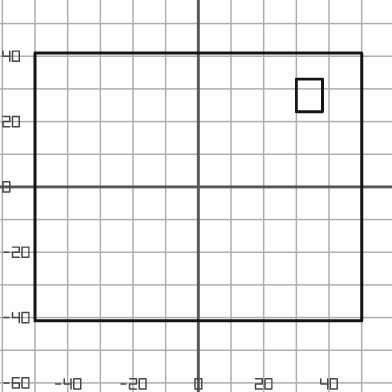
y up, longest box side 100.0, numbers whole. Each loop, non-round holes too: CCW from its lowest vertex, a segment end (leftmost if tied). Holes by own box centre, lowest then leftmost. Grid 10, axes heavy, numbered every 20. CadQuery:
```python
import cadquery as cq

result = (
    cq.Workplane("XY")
    .moveTo(-50.0, -41.0)
    .lineTo(50.0, -41.0)
    .lineTo(50.0, 41.0)
    .lineTo(-50.0, 41.0)
    .close()
    .moveTo(30.0, 23.0)
    .lineTo(38.0, 23.0)
    .lineTo(38.0, 33.0)
    .lineTo(30.0, 33.0)
    .close()
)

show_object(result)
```